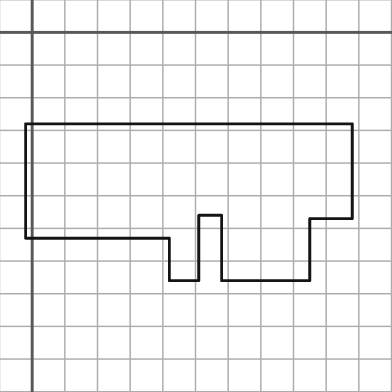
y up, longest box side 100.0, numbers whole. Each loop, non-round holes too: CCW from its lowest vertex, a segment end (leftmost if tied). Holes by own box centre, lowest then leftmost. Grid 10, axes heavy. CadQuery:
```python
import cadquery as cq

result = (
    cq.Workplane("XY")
    .moveTo(42.0, -76.0)
    .lineTo(51.0, -76.0)
    .lineTo(51.0, -56.0)
    .lineTo(58.0, -56.0)
    .lineTo(58.0, -76.0)
    .lineTo(85.0, -76.0)
    .lineTo(85.0, -57.0)
    .lineTo(98.0, -57.0)
    .lineTo(98.0, -28.0)
    .lineTo(-2.0, -28.0)
    .lineTo(-2.0, -63.0)
    .lineTo(42.0, -63.0)
    .close()
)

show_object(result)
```